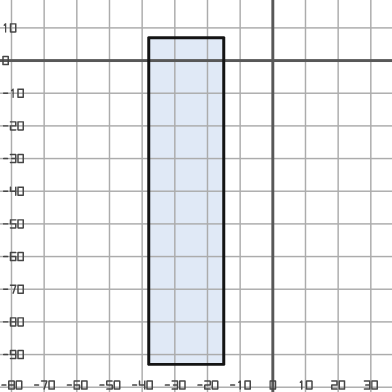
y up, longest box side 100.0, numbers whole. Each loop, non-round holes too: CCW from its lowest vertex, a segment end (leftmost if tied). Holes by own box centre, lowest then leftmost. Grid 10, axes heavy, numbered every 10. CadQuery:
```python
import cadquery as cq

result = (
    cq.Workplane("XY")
    .moveTo(-38.0, -93.0)
    .lineTo(-15.0, -93.0)
    .lineTo(-15.0, 7.0)
    .lineTo(-38.0, 7.0)
    .close()
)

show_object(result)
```